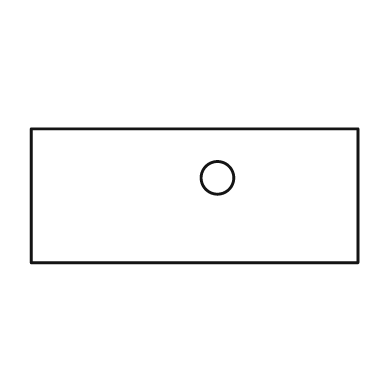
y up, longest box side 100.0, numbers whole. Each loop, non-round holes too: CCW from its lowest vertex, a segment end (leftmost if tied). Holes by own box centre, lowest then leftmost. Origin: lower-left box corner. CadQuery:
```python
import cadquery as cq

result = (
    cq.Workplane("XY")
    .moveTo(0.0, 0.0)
    .lineTo(100.0, 0.0)
    .lineTo(100.0, 41.0)
    .lineTo(0.0, 41.0)
    .close()
    .moveTo(57.0, 26.0)
    .circle(5.0)
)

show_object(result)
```